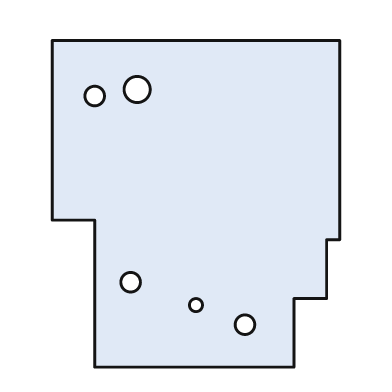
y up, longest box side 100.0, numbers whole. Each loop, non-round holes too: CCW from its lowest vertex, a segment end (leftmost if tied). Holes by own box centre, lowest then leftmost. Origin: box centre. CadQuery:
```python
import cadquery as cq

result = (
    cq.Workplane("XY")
    .moveTo(-31.0, -50.0)
    .lineTo(30.0, -50.0)
    .lineTo(30.0, -29.0)
    .lineTo(40.0, -29.0)
    .lineTo(40.0, -11.0)
    .lineTo(44.0, -11.0)
    .lineTo(44.0, 50.0)
    .lineTo(-44.0, 50.0)
    .lineTo(-44.0, -5.0)
    .lineTo(-31.0, -5.0)
    .close()
    .moveTo(15.0, -37.0)
    .circle(3.0)
    .moveTo(0.0, -31.0)
    .circle(2.0)
    .moveTo(-20.0, -24.0)
    .circle(3.0)
    .moveTo(-31.0, 33.0)
    .circle(3.0)
    .moveTo(-18.0, 35.0)
    .circle(4.0)
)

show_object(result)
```